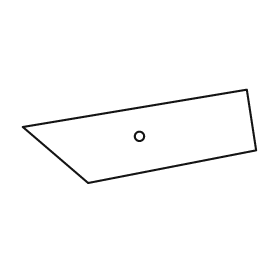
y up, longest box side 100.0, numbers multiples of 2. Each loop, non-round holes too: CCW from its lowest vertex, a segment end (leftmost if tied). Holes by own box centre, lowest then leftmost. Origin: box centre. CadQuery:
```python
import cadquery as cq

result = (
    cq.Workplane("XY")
    .moveTo(-22.0, -20.0)
    .lineTo(50.0, -6.0)
    .lineTo(46.0, 20.0)
    .lineTo(-50.0, 4.0)
    .close()
    .moveTo(0.0, 0.0)
    .circle(2.0)
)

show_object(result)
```